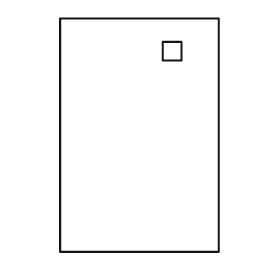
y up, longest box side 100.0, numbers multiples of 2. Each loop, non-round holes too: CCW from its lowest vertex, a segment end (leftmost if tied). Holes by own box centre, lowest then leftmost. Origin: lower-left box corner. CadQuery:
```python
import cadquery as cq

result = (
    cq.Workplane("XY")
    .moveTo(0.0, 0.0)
    .lineTo(68.0, 0.0)
    .lineTo(68.0, 100.0)
    .lineTo(0.0, 100.0)
    .close()
    .moveTo(44.0, 82.0)
    .lineTo(52.0, 82.0)
    .lineTo(52.0, 90.0)
    .lineTo(44.0, 90.0)
    .close()
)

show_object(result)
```